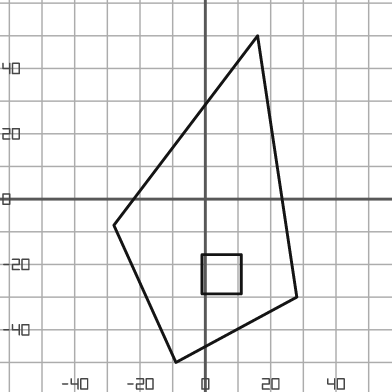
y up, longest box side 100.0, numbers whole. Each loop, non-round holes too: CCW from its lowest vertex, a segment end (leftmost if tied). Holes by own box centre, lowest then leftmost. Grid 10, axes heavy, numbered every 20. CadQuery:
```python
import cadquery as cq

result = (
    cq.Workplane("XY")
    .moveTo(-9.0, -50.0)
    .lineTo(28.0, -30.0)
    .lineTo(16.0, 50.0)
    .lineTo(-28.0, -8.0)
    .close()
    .moveTo(-1.0, -29.0)
    .lineTo(11.0, -29.0)
    .lineTo(11.0, -17.0)
    .lineTo(-1.0, -17.0)
    .close()
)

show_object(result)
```